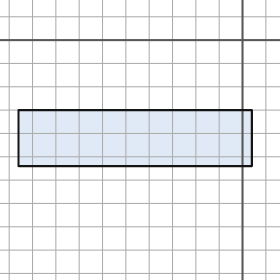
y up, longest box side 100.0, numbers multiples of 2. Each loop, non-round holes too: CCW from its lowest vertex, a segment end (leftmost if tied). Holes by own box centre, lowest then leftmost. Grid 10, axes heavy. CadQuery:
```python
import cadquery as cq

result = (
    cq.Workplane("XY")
    .moveTo(-96.0, -54.0)
    .lineTo(4.0, -54.0)
    .lineTo(4.0, -30.0)
    .lineTo(-96.0, -30.0)
    .close()
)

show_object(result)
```